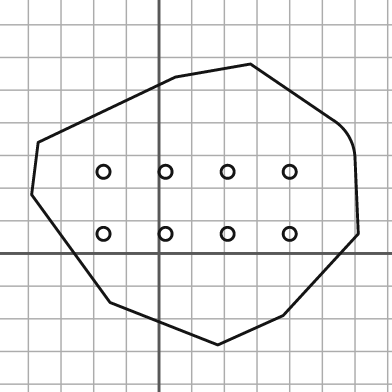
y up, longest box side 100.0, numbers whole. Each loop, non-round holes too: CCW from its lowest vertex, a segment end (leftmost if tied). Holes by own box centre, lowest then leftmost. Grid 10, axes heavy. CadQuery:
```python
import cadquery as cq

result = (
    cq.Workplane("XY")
    .moveTo(18.0, -28.0)
    .lineTo(38.0, -19.0)
    .lineTo(61.0, 6.0)
    .lineTo(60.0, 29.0)
    .threePointArc((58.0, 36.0), (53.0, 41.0))
    .lineTo(28.0, 58.0)
    .lineTo(5.0, 54.0)
    .lineTo(-37.0, 34.0)
    .lineTo(-39.0, 18.0)
    .lineTo(-15.0, -15.0)
    .close()
    .moveTo(-17.0, 6.0)
    .circle(2.0)
    .moveTo(2.0, 6.0)
    .circle(2.0)
    .moveTo(21.0, 6.0)
    .circle(2.0)
    .moveTo(40.0, 6.0)
    .circle(2.0)
    .moveTo(-17.0, 25.0)
    .circle(2.0)
    .moveTo(2.0, 25.0)
    .circle(2.0)
    .moveTo(21.0, 25.0)
    .circle(2.0)
    .moveTo(40.0, 25.0)
    .circle(2.0)
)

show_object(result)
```